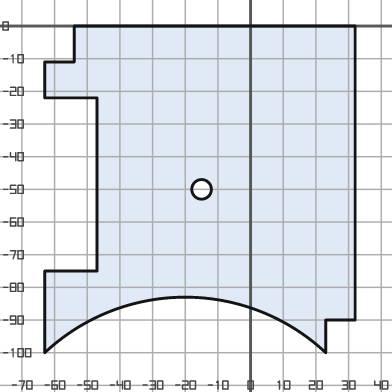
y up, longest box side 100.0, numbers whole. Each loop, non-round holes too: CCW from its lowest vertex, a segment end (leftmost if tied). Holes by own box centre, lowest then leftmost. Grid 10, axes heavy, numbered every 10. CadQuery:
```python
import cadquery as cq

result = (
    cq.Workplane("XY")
    .moveTo(-63.0, -100.0)
    .threePointArc((-20.0, -83.0), (23.0, -100.0))
    .lineTo(23.0, -90.0)
    .lineTo(32.0, -90.0)
    .lineTo(32.0, 0.0)
    .lineTo(-54.0, 0.0)
    .lineTo(-54.0, -11.0)
    .lineTo(-63.0, -11.0)
    .lineTo(-63.0, -22.0)
    .lineTo(-47.0, -22.0)
    .lineTo(-47.0, -75.0)
    .lineTo(-63.0, -75.0)
    .close()
    .moveTo(-15.0, -50.0)
    .circle(3.0)
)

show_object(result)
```